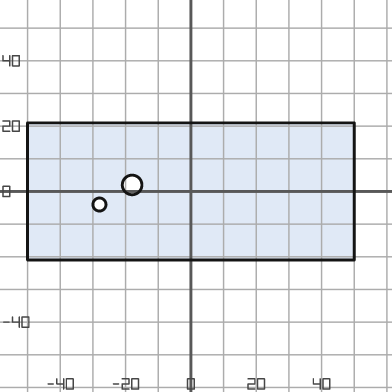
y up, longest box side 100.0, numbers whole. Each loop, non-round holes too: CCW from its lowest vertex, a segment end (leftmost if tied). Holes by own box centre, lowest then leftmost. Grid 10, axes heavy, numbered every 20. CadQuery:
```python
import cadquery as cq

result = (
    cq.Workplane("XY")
    .moveTo(-50.0, -21.0)
    .lineTo(50.0, -21.0)
    .lineTo(50.0, 21.0)
    .lineTo(-50.0, 21.0)
    .close()
    .moveTo(-28.0, -4.0)
    .circle(2.0)
    .moveTo(-18.0, 2.0)
    .circle(3.0)
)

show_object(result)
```